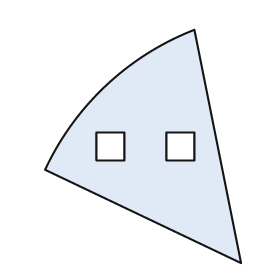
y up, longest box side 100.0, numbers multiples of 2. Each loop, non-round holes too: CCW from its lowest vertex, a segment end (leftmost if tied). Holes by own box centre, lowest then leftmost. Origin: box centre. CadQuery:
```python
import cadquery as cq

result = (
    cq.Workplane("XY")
    .moveTo(42.0, -50.0)
    .lineTo(22.0, 50.0)
    .threePointArc((-16.0, 26.0), (-42.0, -10.0))
    .close()
    .moveTo(-20.0, -6.0)
    .lineTo(-8.0, -6.0)
    .lineTo(-8.0, 6.0)
    .lineTo(-20.0, 6.0)
    .close()
    .moveTo(10.0, -6.0)
    .lineTo(22.0, -6.0)
    .lineTo(22.0, 6.0)
    .lineTo(10.0, 6.0)
    .close()
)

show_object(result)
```